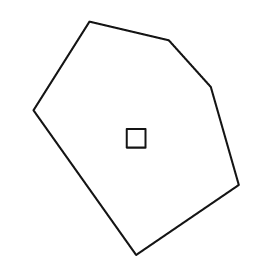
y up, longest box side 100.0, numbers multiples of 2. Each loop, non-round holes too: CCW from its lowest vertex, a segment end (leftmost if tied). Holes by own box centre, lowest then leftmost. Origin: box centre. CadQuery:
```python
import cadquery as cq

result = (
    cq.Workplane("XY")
    .moveTo(0.0, -50.0)
    .lineTo(44.0, -20.0)
    .lineTo(32.0, 22.0)
    .lineTo(14.0, 42.0)
    .lineTo(-20.0, 50.0)
    .lineTo(-44.0, 12.0)
    .close()
    .moveTo(-4.0, -4.0)
    .lineTo(4.0, -4.0)
    .lineTo(4.0, 4.0)
    .lineTo(-4.0, 4.0)
    .close()
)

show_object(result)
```